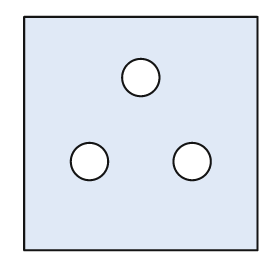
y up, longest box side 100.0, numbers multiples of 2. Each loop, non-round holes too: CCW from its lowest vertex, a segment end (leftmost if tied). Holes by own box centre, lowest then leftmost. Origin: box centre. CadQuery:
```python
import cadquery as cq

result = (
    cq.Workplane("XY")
    .moveTo(-50.0, -50.0)
    .lineTo(50.0, -50.0)
    .lineTo(50.0, 50.0)
    .lineTo(-50.0, 50.0)
    .close()
    .moveTo(-22.0, -12.0)
    .circle(8.0)
    .moveTo(22.0, -12.0)
    .circle(8.0)
    .moveTo(0.0, 24.0)
    .circle(8.0)
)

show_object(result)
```